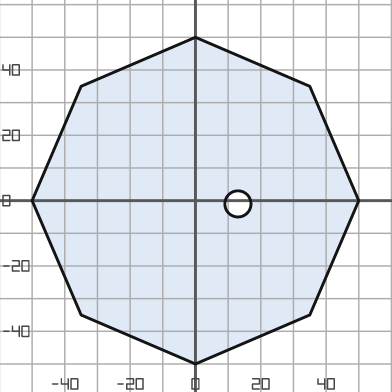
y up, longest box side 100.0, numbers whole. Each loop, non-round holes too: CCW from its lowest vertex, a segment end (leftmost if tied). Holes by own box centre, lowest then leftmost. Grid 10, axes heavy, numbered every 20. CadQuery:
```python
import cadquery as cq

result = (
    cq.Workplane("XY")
    .moveTo(0.0, -50.0)
    .lineTo(35.0, -35.0)
    .lineTo(50.0, 0.0)
    .lineTo(35.0, 35.0)
    .lineTo(0.0, 50.0)
    .lineTo(-35.0, 35.0)
    .lineTo(-50.0, 0.0)
    .lineTo(-35.0, -35.0)
    .close()
    .moveTo(13.0, -1.0)
    .circle(4.0)
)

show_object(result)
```